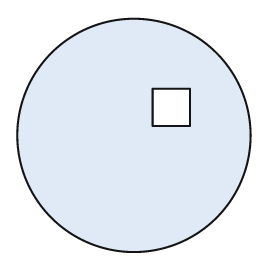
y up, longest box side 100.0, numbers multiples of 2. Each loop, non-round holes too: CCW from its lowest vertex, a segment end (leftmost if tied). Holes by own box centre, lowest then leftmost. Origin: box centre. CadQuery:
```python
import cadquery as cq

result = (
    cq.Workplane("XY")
    .moveTo(0.0, 0.0)
    .circle(50.0)
    .moveTo(8.0, 4.0)
    .lineTo(24.0, 4.0)
    .lineTo(24.0, 20.0)
    .lineTo(8.0, 20.0)
    .close()
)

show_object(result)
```